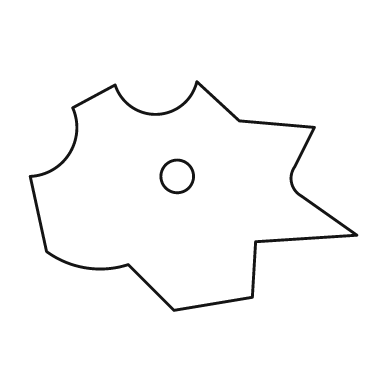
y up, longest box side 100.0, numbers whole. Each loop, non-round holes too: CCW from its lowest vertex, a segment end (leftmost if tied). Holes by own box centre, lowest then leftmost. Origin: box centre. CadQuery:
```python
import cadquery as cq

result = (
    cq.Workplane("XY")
    .moveTo(-6.0, -35.0)
    .lineTo(18.0, -31.0)
    .lineTo(19.0, -14.0)
    .lineTo(50.0, -12.0)
    .lineTo(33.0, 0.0)
    .threePointArc((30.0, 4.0), (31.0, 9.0))
    .lineTo(37.0, 21.0)
    .lineTo(14.0, 23.0)
    .lineTo(1.0, 35.0)
    .threePointArc((-11.0, 25.0), (-24.0, 34.0))
    .lineTo(-37.0, 27.0)
    .threePointArc((-38.0, 13.0), (-50.0, 6.0))
    .lineTo(-45.0, -17.0)
    .threePointArc((-33.0, -22.0), (-20.0, -21.0))
    .close()
    .moveTo(-5.0, 6.0)
    .circle(5.0)
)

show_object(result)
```